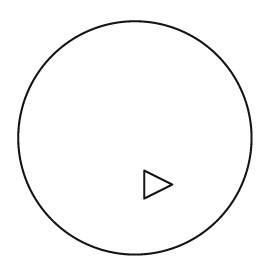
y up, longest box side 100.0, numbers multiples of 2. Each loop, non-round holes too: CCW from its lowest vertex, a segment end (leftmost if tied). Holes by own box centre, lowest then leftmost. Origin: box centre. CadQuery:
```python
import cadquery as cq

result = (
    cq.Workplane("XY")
    .moveTo(0.0, 0.0)
    .circle(50.0)
    .moveTo(4.0, -26.0)
    .lineTo(16.0, -20.0)
    .lineTo(4.0, -14.0)
    .close()
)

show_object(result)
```